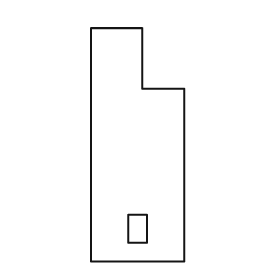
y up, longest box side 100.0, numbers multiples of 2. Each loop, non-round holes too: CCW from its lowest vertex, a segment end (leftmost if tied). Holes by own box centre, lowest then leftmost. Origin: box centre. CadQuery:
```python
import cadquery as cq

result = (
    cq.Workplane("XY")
    .moveTo(-20.0, -50.0)
    .lineTo(20.0, -50.0)
    .lineTo(20.0, 24.0)
    .lineTo(2.0, 24.0)
    .lineTo(2.0, 50.0)
    .lineTo(-20.0, 50.0)
    .close()
    .moveTo(-4.0, -42.0)
    .lineTo(4.0, -42.0)
    .lineTo(4.0, -30.0)
    .lineTo(-4.0, -30.0)
    .close()
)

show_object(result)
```